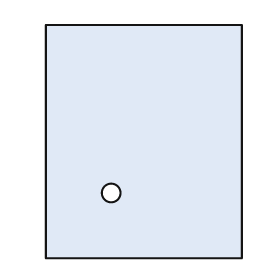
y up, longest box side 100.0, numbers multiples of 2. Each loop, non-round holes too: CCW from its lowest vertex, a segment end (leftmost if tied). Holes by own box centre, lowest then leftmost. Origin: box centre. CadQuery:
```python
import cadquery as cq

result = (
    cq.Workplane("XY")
    .moveTo(-42.0, -50.0)
    .lineTo(42.0, -50.0)
    .lineTo(42.0, 50.0)
    .lineTo(-42.0, 50.0)
    .close()
    .moveTo(-14.0, -22.0)
    .circle(4.0)
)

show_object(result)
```